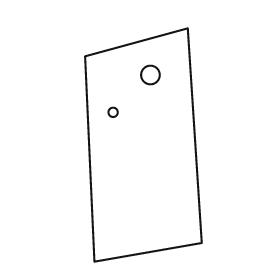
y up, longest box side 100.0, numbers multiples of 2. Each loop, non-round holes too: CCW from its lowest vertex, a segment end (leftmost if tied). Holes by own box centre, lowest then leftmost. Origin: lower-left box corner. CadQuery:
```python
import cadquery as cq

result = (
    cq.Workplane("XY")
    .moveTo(4.0, 0.0)
    .lineTo(50.0, 8.0)
    .lineTo(44.0, 100.0)
    .lineTo(0.0, 88.0)
    .close()
    .moveTo(12.0, 64.0)
    .circle(2.0)
    .moveTo(28.0, 80.0)
    .circle(4.0)
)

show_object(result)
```